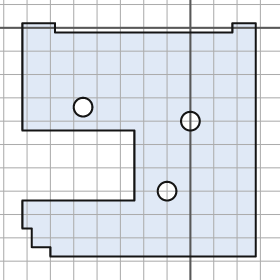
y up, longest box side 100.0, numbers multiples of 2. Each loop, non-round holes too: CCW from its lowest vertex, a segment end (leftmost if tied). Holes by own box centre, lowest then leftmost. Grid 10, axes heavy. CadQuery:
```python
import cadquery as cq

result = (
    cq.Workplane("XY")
    .moveTo(-60.0, -98.0)
    .lineTo(28.0, -98.0)
    .lineTo(28.0, 2.0)
    .lineTo(18.0, 2.0)
    .lineTo(18.0, -2.0)
    .lineTo(-58.0, -2.0)
    .lineTo(-58.0, 2.0)
    .lineTo(-72.0, 2.0)
    .lineTo(-72.0, -44.0)
    .lineTo(-24.0, -44.0)
    .lineTo(-24.0, -74.0)
    .lineTo(-72.0, -74.0)
    .lineTo(-72.0, -86.0)
    .lineTo(-68.0, -86.0)
    .lineTo(-68.0, -94.0)
    .lineTo(-60.0, -94.0)
    .close()
    .moveTo(-10.0, -70.0)
    .circle(4.0)
    .moveTo(0.0, -40.0)
    .circle(4.0)
    .moveTo(-46.0, -34.0)
    .circle(4.0)
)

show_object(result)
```